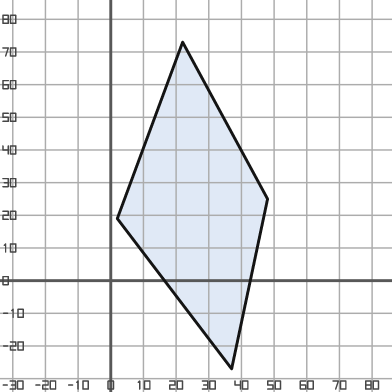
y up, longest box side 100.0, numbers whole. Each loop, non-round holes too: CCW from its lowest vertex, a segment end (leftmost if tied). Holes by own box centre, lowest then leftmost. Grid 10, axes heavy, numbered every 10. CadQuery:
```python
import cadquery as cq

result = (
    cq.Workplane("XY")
    .moveTo(37.0, -27.0)
    .lineTo(48.0, 25.0)
    .lineTo(22.0, 73.0)
    .lineTo(2.0, 19.0)
    .close()
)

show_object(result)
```